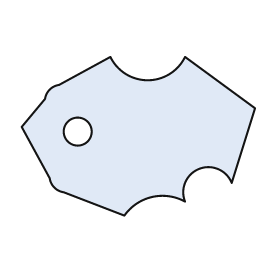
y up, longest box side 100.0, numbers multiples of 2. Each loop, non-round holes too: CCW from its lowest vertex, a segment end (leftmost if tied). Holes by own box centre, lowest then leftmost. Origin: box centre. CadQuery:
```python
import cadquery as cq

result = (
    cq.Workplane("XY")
    .moveTo(-6.0, -34.0)
    .threePointArc((6.0, -26.0), (20.0, -28.0))
    .threePointArc((26.0, -14.0), (40.0, -20.0))
    .lineTo(50.0, 12.0)
    .lineTo(20.0, 34.0)
    .threePointArc((4.0, 24.0), (-12.0, 34.0))
    .lineTo(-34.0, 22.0)
    .threePointArc((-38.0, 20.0), (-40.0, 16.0))
    .lineTo(-50.0, 4.0)
    .lineTo(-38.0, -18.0)
    .threePointArc((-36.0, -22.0), (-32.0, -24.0))
    .close()
    .moveTo(-26.0, 2.0)
    .circle(6.0)
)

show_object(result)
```